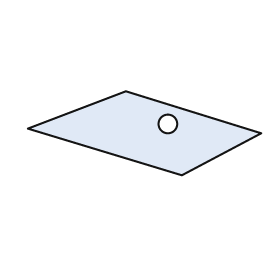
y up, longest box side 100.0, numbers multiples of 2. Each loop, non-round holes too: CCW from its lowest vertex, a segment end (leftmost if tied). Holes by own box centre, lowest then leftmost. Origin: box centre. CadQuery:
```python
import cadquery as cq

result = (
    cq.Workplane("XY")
    .moveTo(16.0, -18.0)
    .lineTo(50.0, 0.0)
    .lineTo(-8.0, 18.0)
    .lineTo(-50.0, 2.0)
    .close()
    .moveTo(10.0, 4.0)
    .circle(4.0)
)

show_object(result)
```